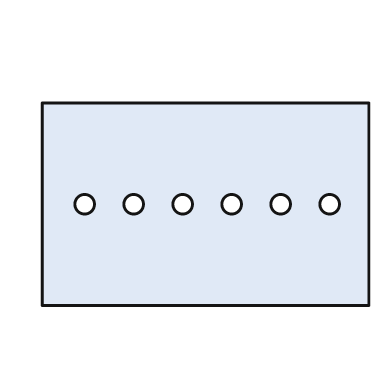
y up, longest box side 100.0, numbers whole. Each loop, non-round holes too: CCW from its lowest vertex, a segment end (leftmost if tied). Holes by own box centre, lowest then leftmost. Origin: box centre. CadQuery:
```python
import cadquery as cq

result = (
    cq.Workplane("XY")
    .moveTo(-50.0, -31.0)
    .lineTo(50.0, -31.0)
    .lineTo(50.0, 31.0)
    .lineTo(-50.0, 31.0)
    .close()
    .moveTo(-37.0, 0.0)
    .circle(3.0)
    .moveTo(-22.0, 0.0)
    .circle(3.0)
    .moveTo(-7.0, 0.0)
    .circle(3.0)
    .moveTo(8.0, 0.0)
    .circle(3.0)
    .moveTo(23.0, 0.0)
    .circle(3.0)
    .moveTo(38.0, 0.0)
    .circle(3.0)
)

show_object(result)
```